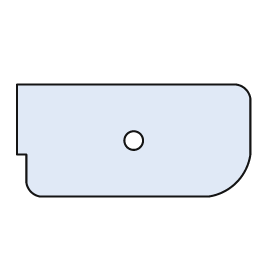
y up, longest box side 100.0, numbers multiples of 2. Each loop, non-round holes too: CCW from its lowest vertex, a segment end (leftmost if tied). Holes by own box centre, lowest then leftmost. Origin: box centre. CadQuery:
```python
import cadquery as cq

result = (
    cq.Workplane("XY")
    .moveTo(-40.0, -24.0)
    .lineTo(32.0, -24.0)
    .threePointArc((44.0, -18.0), (50.0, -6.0))
    .lineTo(50.0, 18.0)
    .threePointArc((48.0, 22.0), (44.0, 24.0))
    .lineTo(-50.0, 24.0)
    .lineTo(-50.0, -6.0)
    .lineTo(-46.0, -6.0)
    .lineTo(-46.0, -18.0)
    .threePointArc((-44.0, -22.0), (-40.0, -24.0))
    .close()
    .moveTo(0.0, 0.0)
    .circle(4.0)
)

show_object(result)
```